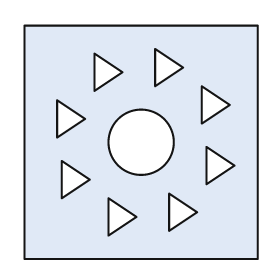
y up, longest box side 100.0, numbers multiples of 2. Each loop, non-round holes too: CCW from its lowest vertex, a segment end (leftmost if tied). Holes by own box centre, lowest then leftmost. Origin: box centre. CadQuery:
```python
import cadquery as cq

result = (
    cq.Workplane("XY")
    .moveTo(-50.0, -50.0)
    .lineTo(50.0, -50.0)
    .lineTo(50.0, 50.0)
    .lineTo(-50.0, 50.0)
    .close()
    .moveTo(-14.0, -40.0)
    .lineTo(-2.0, -32.0)
    .lineTo(-14.0, -24.0)
    .close()
    .moveTo(12.0, -38.0)
    .lineTo(24.0, -30.0)
    .lineTo(12.0, -22.0)
    .close()
    .moveTo(-34.0, -24.0)
    .lineTo(-22.0, -16.0)
    .lineTo(-34.0, -8.0)
    .close()
    .moveTo(28.0, -18.0)
    .lineTo(40.0, -10.0)
    .lineTo(28.0, -2.0)
    .close()
    .moveTo(0.0, 0.0)
    .circle(14.0)
    .moveTo(-36.0, 2.0)
    .lineTo(-24.0, 10.0)
    .lineTo(-36.0, 18.0)
    .close()
    .moveTo(26.0, 8.0)
    .lineTo(38.0, 16.0)
    .lineTo(26.0, 24.0)
    .close()
    .moveTo(-20.0, 22.0)
    .lineTo(-8.0, 30.0)
    .lineTo(-20.0, 38.0)
    .close()
    .moveTo(6.0, 24.0)
    .lineTo(18.0, 32.0)
    .lineTo(6.0, 40.0)
    .close()
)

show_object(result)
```